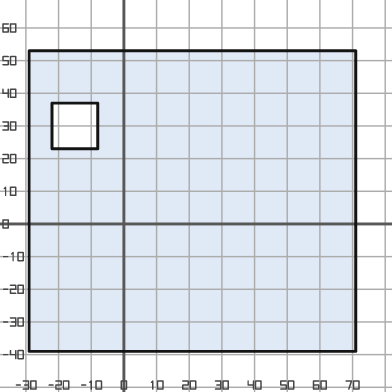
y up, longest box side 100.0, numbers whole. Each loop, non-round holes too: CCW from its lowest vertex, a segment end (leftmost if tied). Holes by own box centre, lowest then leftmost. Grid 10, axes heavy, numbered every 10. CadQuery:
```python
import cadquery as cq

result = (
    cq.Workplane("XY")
    .moveTo(-29.0, -39.0)
    .lineTo(71.0, -39.0)
    .lineTo(71.0, 53.0)
    .lineTo(-29.0, 53.0)
    .close()
    .moveTo(-22.0, 23.0)
    .lineTo(-8.0, 23.0)
    .lineTo(-8.0, 37.0)
    .lineTo(-22.0, 37.0)
    .close()
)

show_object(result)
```